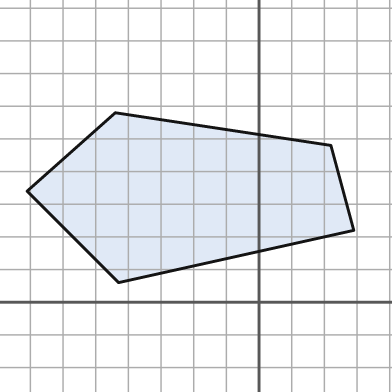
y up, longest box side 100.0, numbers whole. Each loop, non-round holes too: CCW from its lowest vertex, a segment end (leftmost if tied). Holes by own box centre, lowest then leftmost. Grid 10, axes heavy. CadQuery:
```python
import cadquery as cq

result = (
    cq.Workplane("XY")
    .moveTo(-43.0, 6.0)
    .lineTo(29.0, 22.0)
    .lineTo(22.0, 48.0)
    .lineTo(-44.0, 58.0)
    .lineTo(-71.0, 34.0)
    .close()
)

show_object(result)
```